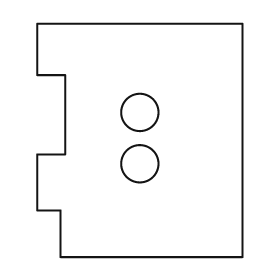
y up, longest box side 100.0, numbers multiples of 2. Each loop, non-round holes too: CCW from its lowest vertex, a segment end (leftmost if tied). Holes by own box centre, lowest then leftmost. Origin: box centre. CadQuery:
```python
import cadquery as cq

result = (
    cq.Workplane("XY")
    .moveTo(-34.0, -50.0)
    .lineTo(44.0, -50.0)
    .lineTo(44.0, 50.0)
    .lineTo(-44.0, 50.0)
    .lineTo(-44.0, 28.0)
    .lineTo(-32.0, 28.0)
    .lineTo(-32.0, -6.0)
    .lineTo(-44.0, -6.0)
    .lineTo(-44.0, -30.0)
    .lineTo(-34.0, -30.0)
    .close()
    .moveTo(0.0, -10.0)
    .circle(8.0)
    .moveTo(0.0, 12.0)
    .circle(8.0)
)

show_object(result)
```